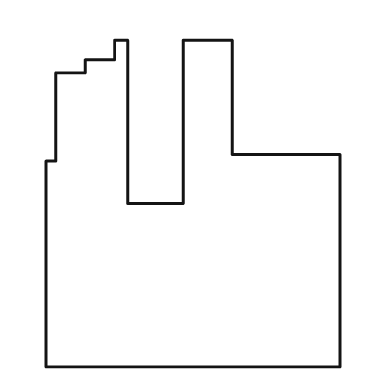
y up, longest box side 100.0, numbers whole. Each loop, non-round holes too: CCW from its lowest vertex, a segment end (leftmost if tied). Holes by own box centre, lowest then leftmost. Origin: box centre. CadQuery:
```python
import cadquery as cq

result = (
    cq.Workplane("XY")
    .moveTo(-45.0, -50.0)
    .lineTo(45.0, -50.0)
    .lineTo(45.0, 15.0)
    .lineTo(12.0, 15.0)
    .lineTo(12.0, 50.0)
    .lineTo(-3.0, 50.0)
    .lineTo(-3.0, 0.0)
    .lineTo(-20.0, 0.0)
    .lineTo(-20.0, 50.0)
    .lineTo(-24.0, 50.0)
    .lineTo(-24.0, 44.0)
    .lineTo(-33.0, 44.0)
    .lineTo(-33.0, 40.0)
    .lineTo(-42.0, 40.0)
    .lineTo(-42.0, 13.0)
    .lineTo(-45.0, 13.0)
    .close()
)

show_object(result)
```